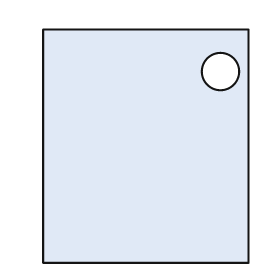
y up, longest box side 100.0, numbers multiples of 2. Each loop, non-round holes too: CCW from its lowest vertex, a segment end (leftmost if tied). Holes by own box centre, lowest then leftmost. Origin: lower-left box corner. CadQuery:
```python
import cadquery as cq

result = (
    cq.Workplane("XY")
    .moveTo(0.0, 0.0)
    .lineTo(88.0, 0.0)
    .lineTo(88.0, 100.0)
    .lineTo(0.0, 100.0)
    .close()
    .moveTo(76.0, 82.0)
    .circle(8.0)
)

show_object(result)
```